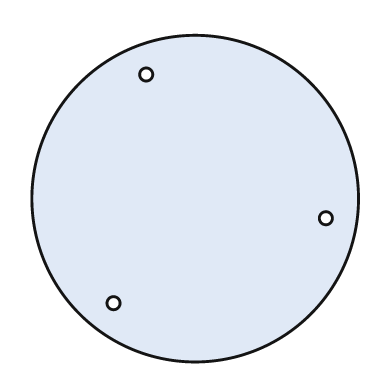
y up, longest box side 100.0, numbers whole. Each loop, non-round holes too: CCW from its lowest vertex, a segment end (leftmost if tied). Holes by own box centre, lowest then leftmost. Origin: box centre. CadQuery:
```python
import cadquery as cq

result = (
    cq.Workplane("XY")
    .moveTo(0.0, 0.0)
    .circle(50.0)
    .moveTo(-25.0, -32.0)
    .circle(2.0)
    .moveTo(40.0, -6.0)
    .circle(2.0)
    .moveTo(-15.0, 38.0)
    .circle(2.0)
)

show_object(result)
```